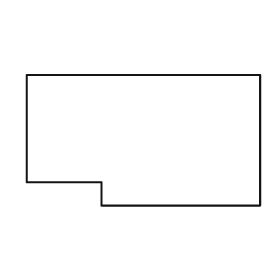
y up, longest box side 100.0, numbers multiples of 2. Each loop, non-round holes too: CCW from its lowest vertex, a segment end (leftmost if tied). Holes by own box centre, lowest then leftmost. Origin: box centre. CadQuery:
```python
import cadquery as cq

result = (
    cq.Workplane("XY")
    .moveTo(-18.0, -28.0)
    .lineTo(50.0, -28.0)
    .lineTo(50.0, 28.0)
    .lineTo(-50.0, 28.0)
    .lineTo(-50.0, -18.0)
    .lineTo(-18.0, -18.0)
    .close()
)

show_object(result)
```